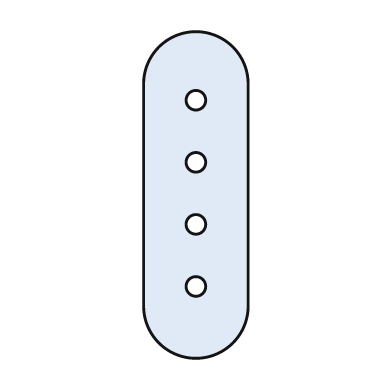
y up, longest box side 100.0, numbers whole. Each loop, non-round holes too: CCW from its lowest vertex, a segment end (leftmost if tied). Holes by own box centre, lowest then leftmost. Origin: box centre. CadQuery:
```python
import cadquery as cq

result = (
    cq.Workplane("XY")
    .moveTo(-16.0, -34.0)
    .threePointArc((0.0, -50.0), (16.0, -34.0))
    .lineTo(16.0, 34.0)
    .threePointArc((0.0, 50.0), (-16.0, 34.0))
    .close()
    .moveTo(0.0, -28.0)
    .circle(3.0)
    .moveTo(0.0, -9.0)
    .circle(3.0)
    .moveTo(0.0, 10.0)
    .circle(3.0)
    .moveTo(0.0, 29.0)
    .circle(3.0)
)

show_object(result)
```